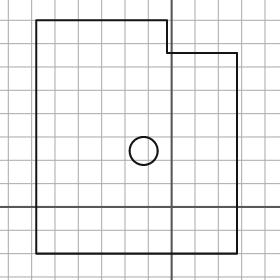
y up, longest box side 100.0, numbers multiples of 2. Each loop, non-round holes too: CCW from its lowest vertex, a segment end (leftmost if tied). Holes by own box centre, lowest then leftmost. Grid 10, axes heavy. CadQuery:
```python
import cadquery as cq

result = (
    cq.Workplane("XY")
    .moveTo(-58.0, -20.0)
    .lineTo(28.0, -20.0)
    .lineTo(28.0, 66.0)
    .lineTo(-2.0, 66.0)
    .lineTo(-2.0, 80.0)
    .lineTo(-58.0, 80.0)
    .close()
    .moveTo(-12.0, 24.0)
    .circle(6.0)
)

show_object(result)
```